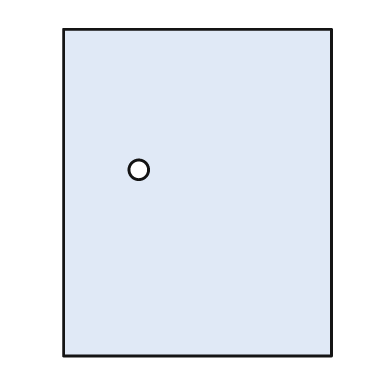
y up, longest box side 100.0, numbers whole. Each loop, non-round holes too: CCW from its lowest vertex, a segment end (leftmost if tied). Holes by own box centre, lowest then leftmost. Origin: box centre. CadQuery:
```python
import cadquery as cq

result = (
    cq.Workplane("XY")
    .moveTo(-41.0, -50.0)
    .lineTo(41.0, -50.0)
    .lineTo(41.0, 50.0)
    .lineTo(-41.0, 50.0)
    .close()
    .moveTo(-18.0, 7.0)
    .circle(3.0)
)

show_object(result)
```